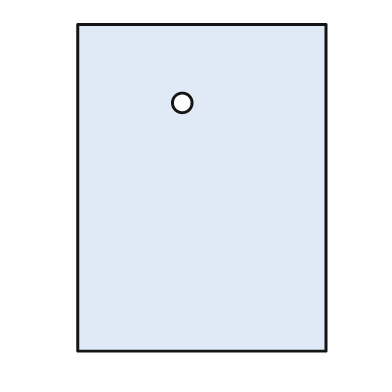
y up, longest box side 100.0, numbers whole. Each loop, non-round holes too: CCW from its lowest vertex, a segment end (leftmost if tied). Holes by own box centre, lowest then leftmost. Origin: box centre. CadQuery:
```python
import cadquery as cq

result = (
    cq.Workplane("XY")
    .moveTo(-38.0, -50.0)
    .lineTo(38.0, -50.0)
    .lineTo(38.0, 50.0)
    .lineTo(-38.0, 50.0)
    .close()
    .moveTo(-6.0, 26.0)
    .circle(3.0)
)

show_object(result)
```